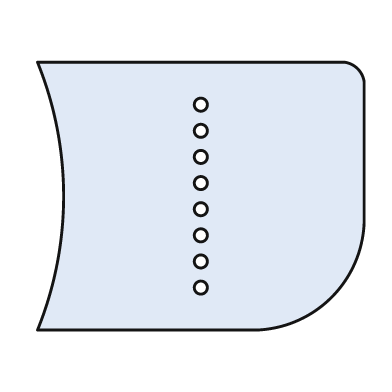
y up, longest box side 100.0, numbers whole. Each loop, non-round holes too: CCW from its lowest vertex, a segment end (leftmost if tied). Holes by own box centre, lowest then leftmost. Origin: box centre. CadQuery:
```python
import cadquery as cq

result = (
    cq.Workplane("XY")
    .moveTo(-50.0, -41.0)
    .lineTo(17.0, -41.0)
    .threePointArc((40.0, -31.0), (50.0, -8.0))
    .lineTo(50.0, 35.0)
    .threePointArc((48.0, 39.0), (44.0, 41.0))
    .lineTo(-50.0, 41.0)
    .threePointArc((-42.0, 0.0), (-50.0, -41.0))
    .close()
    .moveTo(0.0, -28.0)
    .circle(2.0)
    .moveTo(0.0, -20.0)
    .circle(2.0)
    .moveTo(0.0, -12.0)
    .circle(2.0)
    .moveTo(0.0, -4.0)
    .circle(2.0)
    .moveTo(0.0, 4.0)
    .circle(2.0)
    .moveTo(0.0, 12.0)
    .circle(2.0)
    .moveTo(0.0, 20.0)
    .circle(2.0)
    .moveTo(0.0, 28.0)
    .circle(2.0)
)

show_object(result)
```